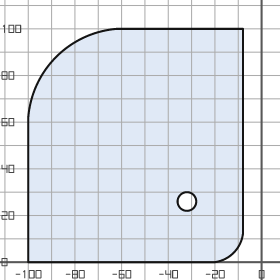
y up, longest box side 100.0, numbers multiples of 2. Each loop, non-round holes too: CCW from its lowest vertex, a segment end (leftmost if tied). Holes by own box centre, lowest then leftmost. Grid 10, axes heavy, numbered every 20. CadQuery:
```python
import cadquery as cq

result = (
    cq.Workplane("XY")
    .moveTo(-100.0, 0.0)
    .lineTo(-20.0, 0.0)
    .threePointArc((-12.0, 4.0), (-8.0, 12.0))
    .lineTo(-8.0, 100.0)
    .lineTo(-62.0, 100.0)
    .threePointArc((-88.0, 88.0), (-100.0, 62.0))
    .close()
    .moveTo(-32.0, 26.0)
    .circle(4.0)
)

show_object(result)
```